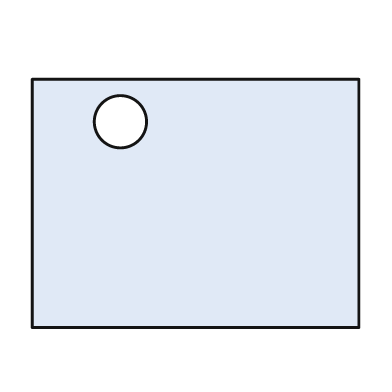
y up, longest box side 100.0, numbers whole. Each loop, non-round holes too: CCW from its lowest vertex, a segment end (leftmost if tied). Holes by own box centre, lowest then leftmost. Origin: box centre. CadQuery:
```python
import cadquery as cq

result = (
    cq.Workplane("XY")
    .moveTo(-50.0, -38.0)
    .lineTo(50.0, -38.0)
    .lineTo(50.0, 38.0)
    .lineTo(-50.0, 38.0)
    .close()
    .moveTo(-23.0, 25.0)
    .circle(8.0)
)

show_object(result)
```